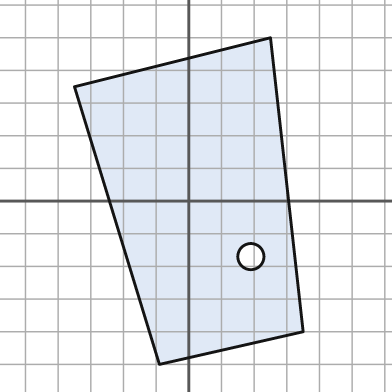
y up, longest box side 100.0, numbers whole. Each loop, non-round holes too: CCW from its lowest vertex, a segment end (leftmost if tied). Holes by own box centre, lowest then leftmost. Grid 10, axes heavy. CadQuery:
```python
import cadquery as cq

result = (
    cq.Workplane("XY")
    .moveTo(-9.0, -50.0)
    .lineTo(35.0, -40.0)
    .lineTo(25.0, 50.0)
    .lineTo(-35.0, 35.0)
    .close()
    .moveTo(19.0, -17.0)
    .circle(4.0)
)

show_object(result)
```